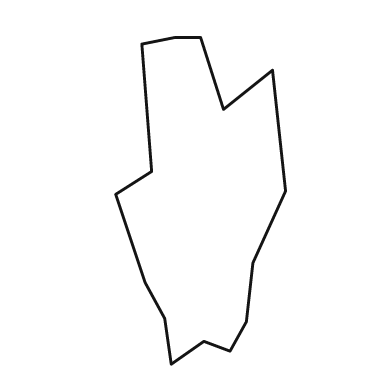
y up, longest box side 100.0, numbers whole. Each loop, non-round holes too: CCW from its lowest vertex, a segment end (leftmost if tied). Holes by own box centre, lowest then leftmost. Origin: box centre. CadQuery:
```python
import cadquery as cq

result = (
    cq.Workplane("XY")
    .moveTo(-9.0, -50.0)
    .lineTo(1.0, -43.0)
    .lineTo(9.0, -46.0)
    .lineTo(14.0, -37.0)
    .lineTo(16.0, -19.0)
    .lineTo(26.0, 3.0)
    .lineTo(22.0, 40.0)
    .lineTo(7.0, 28.0)
    .lineTo(0.0, 50.0)
    .lineTo(-8.0, 50.0)
    .lineTo(-18.0, 48.0)
    .lineTo(-15.0, 9.0)
    .lineTo(-26.0, 2.0)
    .lineTo(-17.0, -25.0)
    .lineTo(-11.0, -36.0)
    .close()
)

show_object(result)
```